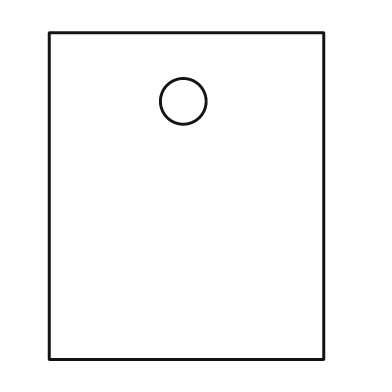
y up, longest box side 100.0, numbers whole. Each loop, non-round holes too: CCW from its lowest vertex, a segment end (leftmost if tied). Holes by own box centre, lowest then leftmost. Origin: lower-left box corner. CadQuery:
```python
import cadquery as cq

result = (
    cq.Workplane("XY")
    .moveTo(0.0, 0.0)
    .lineTo(84.0, 0.0)
    .lineTo(84.0, 100.0)
    .lineTo(0.0, 100.0)
    .close()
    .moveTo(41.0, 79.0)
    .circle(7.0)
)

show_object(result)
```